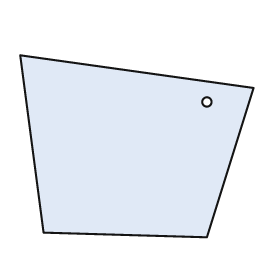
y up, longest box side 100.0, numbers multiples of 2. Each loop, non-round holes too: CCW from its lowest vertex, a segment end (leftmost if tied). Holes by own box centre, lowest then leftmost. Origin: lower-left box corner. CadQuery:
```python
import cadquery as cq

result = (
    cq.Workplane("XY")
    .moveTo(80.0, 0.0)
    .lineTo(100.0, 64.0)
    .lineTo(0.0, 78.0)
    .lineTo(10.0, 2.0)
    .close()
    .moveTo(80.0, 58.0)
    .circle(2.0)
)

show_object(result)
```